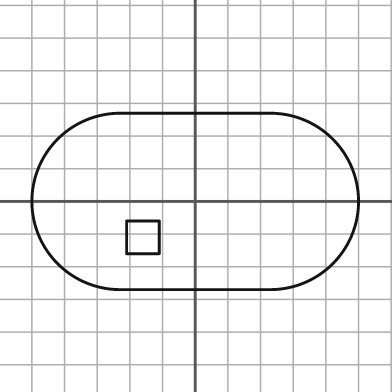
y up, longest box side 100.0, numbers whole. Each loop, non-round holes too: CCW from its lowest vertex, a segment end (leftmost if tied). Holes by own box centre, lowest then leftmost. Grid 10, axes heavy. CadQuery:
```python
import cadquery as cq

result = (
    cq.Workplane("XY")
    .moveTo(-23.0, -27.0)
    .lineTo(23.0, -27.0)
    .threePointArc((50.0, 0.0), (23.0, 27.0))
    .lineTo(-23.0, 27.0)
    .threePointArc((-50.0, 0.0), (-23.0, -27.0))
    .close()
    .moveTo(-21.0, -16.0)
    .lineTo(-11.0, -16.0)
    .lineTo(-11.0, -6.0)
    .lineTo(-21.0, -6.0)
    .close()
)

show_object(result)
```